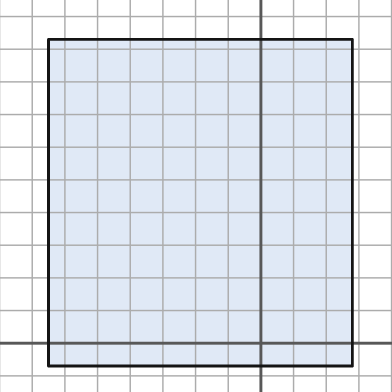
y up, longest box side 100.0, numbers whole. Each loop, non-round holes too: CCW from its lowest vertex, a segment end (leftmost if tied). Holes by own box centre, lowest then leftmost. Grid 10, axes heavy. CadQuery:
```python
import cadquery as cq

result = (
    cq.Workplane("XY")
    .moveTo(-65.0, -7.0)
    .lineTo(28.0, -7.0)
    .lineTo(28.0, 93.0)
    .lineTo(-65.0, 93.0)
    .close()
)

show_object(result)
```